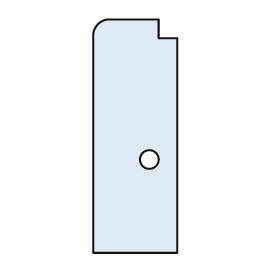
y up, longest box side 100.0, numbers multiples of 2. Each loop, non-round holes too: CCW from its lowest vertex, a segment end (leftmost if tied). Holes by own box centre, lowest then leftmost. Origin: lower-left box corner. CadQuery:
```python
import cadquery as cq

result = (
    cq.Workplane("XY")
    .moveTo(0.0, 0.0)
    .lineTo(36.0, 0.0)
    .lineTo(36.0, 92.0)
    .lineTo(28.0, 92.0)
    .lineTo(28.0, 100.0)
    .lineTo(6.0, 100.0)
    .threePointArc((2.0, 98.0), (0.0, 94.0))
    .close()
    .moveTo(24.0, 40.0)
    .circle(4.0)
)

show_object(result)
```